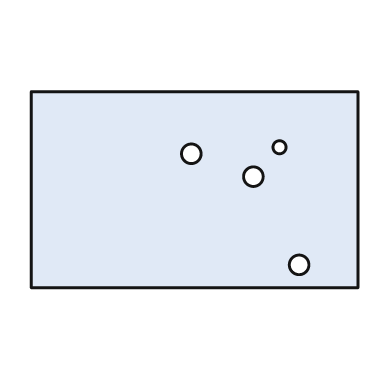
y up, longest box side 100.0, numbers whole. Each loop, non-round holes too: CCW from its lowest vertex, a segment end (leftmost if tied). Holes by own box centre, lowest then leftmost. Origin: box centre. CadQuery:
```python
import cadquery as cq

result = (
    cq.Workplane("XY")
    .moveTo(-50.0, -30.0)
    .lineTo(50.0, -30.0)
    .lineTo(50.0, 30.0)
    .lineTo(-50.0, 30.0)
    .close()
    .moveTo(32.0, -23.0)
    .circle(3.0)
    .moveTo(18.0, 4.0)
    .circle(3.0)
    .moveTo(-1.0, 11.0)
    .circle(3.0)
    .moveTo(26.0, 13.0)
    .circle(2.0)
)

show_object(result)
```